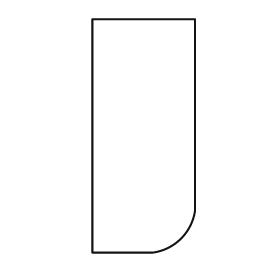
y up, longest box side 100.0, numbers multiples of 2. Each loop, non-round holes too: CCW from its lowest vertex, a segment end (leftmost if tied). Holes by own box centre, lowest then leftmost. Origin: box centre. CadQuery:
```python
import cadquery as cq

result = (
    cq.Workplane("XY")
    .moveTo(-22.0, -50.0)
    .lineTo(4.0, -50.0)
    .threePointArc((16.0, -44.0), (22.0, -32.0))
    .lineTo(22.0, 50.0)
    .lineTo(-22.0, 50.0)
    .close()
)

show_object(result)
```